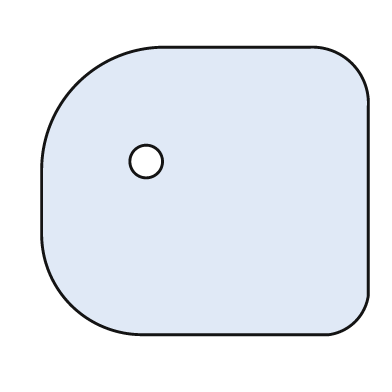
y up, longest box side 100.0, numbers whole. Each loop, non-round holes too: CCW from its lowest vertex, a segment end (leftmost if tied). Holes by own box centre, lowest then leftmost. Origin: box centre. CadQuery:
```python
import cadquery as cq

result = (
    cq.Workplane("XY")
    .moveTo(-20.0, -44.0)
    .lineTo(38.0, -44.0)
    .threePointArc((46.0, -40.0), (50.0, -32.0))
    .lineTo(50.0, 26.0)
    .threePointArc((45.0, 39.0), (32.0, 44.0))
    .lineTo(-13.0, 44.0)
    .threePointArc((-39.0, 33.0), (-50.0, 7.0))
    .lineTo(-50.0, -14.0)
    .threePointArc((-41.0, -35.0), (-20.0, -44.0))
    .close()
    .moveTo(-18.0, 9.0)
    .circle(5.0)
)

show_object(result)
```